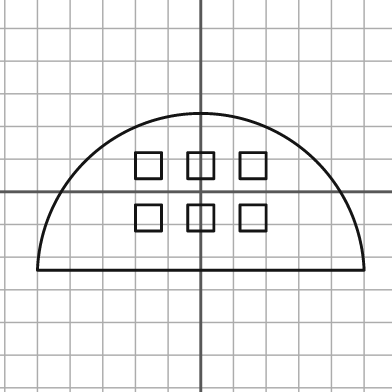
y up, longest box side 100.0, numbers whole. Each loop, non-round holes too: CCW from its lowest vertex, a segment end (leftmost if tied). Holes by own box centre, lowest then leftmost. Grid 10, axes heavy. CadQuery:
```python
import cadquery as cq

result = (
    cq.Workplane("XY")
    .moveTo(-50.0, -24.0)
    .lineTo(50.0, -24.0)
    .threePointArc((0.0, 24.0), (-50.0, -24.0))
    .close()
    .moveTo(-20.0, -12.0)
    .lineTo(-12.0, -12.0)
    .lineTo(-12.0, -4.0)
    .lineTo(-20.0, -4.0)
    .close()
    .moveTo(-4.0, -12.0)
    .lineTo(4.0, -12.0)
    .lineTo(4.0, -4.0)
    .lineTo(-4.0, -4.0)
    .close()
    .moveTo(12.0, -12.0)
    .lineTo(20.0, -12.0)
    .lineTo(20.0, -4.0)
    .lineTo(12.0, -4.0)
    .close()
    .moveTo(-20.0, 4.0)
    .lineTo(-12.0, 4.0)
    .lineTo(-12.0, 12.0)
    .lineTo(-20.0, 12.0)
    .close()
    .moveTo(-4.0, 4.0)
    .lineTo(4.0, 4.0)
    .lineTo(4.0, 12.0)
    .lineTo(-4.0, 12.0)
    .close()
    .moveTo(12.0, 4.0)
    .lineTo(20.0, 4.0)
    .lineTo(20.0, 12.0)
    .lineTo(12.0, 12.0)
    .close()
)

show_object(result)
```